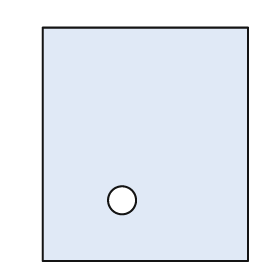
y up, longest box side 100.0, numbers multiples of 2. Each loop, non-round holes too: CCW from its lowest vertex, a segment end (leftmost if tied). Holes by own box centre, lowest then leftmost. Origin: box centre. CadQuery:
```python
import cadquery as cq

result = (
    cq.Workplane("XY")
    .moveTo(-44.0, -50.0)
    .lineTo(44.0, -50.0)
    .lineTo(44.0, 50.0)
    .lineTo(-44.0, 50.0)
    .close()
    .moveTo(-10.0, -24.0)
    .circle(6.0)
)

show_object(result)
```